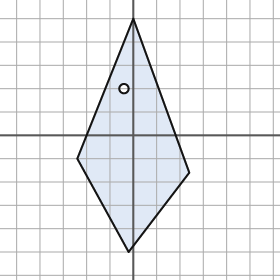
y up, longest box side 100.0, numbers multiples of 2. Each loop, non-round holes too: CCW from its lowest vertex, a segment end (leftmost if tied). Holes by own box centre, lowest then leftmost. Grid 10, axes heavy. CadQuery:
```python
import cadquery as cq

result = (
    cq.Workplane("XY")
    .moveTo(-2.0, -50.0)
    .lineTo(24.0, -16.0)
    .lineTo(0.0, 50.0)
    .lineTo(-24.0, -10.0)
    .close()
    .moveTo(-4.0, 20.0)
    .circle(2.0)
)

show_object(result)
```